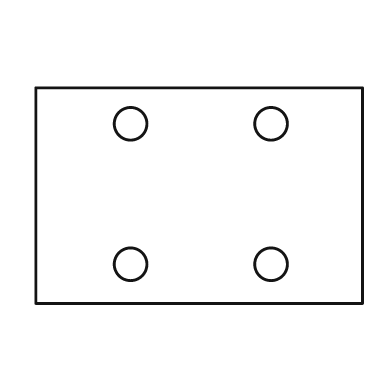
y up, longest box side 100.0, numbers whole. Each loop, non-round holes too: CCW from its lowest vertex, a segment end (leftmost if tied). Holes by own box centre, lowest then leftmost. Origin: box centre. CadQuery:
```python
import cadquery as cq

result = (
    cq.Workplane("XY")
    .moveTo(-50.0, -33.0)
    .lineTo(50.0, -33.0)
    .lineTo(50.0, 33.0)
    .lineTo(-50.0, 33.0)
    .close()
    .moveTo(-21.0, -21.0)
    .circle(5.0)
    .moveTo(22.0, -21.0)
    .circle(5.0)
    .moveTo(-21.0, 22.0)
    .circle(5.0)
    .moveTo(22.0, 22.0)
    .circle(5.0)
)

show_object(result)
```